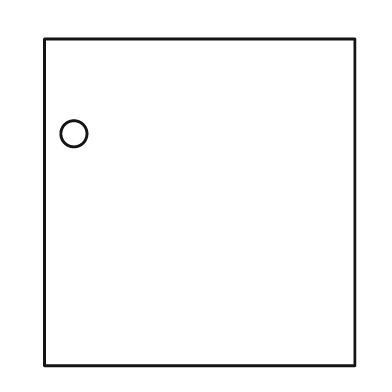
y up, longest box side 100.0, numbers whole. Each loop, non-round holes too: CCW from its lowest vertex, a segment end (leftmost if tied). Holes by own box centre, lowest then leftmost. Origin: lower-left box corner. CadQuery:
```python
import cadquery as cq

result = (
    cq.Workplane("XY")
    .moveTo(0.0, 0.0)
    .lineTo(95.0, 0.0)
    .lineTo(95.0, 100.0)
    .lineTo(0.0, 100.0)
    .close()
    .moveTo(9.0, 71.0)
    .circle(4.0)
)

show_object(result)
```